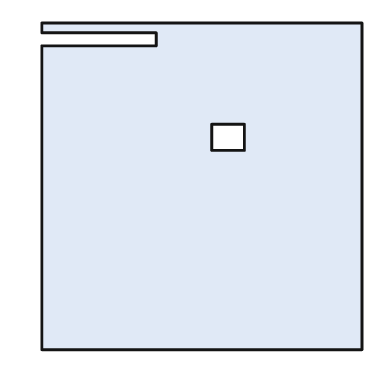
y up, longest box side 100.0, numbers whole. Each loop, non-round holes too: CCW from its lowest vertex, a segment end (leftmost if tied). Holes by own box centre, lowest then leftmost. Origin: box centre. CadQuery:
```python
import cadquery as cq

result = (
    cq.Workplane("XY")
    .moveTo(-49.0, -50.0)
    .lineTo(49.0, -50.0)
    .lineTo(49.0, 50.0)
    .lineTo(-49.0, 50.0)
    .lineTo(-49.0, 47.0)
    .lineTo(-14.0, 47.0)
    .lineTo(-14.0, 43.0)
    .lineTo(-49.0, 43.0)
    .close()
    .moveTo(3.0, 11.0)
    .lineTo(13.0, 11.0)
    .lineTo(13.0, 19.0)
    .lineTo(3.0, 19.0)
    .close()
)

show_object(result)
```